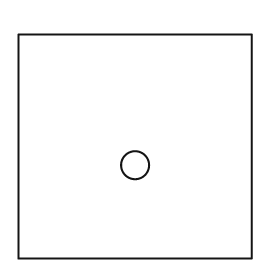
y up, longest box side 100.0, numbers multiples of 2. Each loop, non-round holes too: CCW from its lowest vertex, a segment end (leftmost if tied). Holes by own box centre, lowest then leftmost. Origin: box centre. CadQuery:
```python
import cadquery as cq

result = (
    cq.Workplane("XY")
    .moveTo(-50.0, -48.0)
    .lineTo(50.0, -48.0)
    .lineTo(50.0, 48.0)
    .lineTo(-50.0, 48.0)
    .close()
    .moveTo(0.0, -8.0)
    .circle(6.0)
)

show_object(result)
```